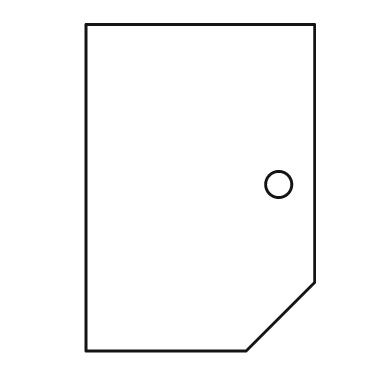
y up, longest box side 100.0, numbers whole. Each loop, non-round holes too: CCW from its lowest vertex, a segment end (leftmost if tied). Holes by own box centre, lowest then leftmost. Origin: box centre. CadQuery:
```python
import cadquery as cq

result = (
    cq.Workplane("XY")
    .moveTo(-35.0, -50.0)
    .lineTo(14.0, -50.0)
    .lineTo(35.0, -29.0)
    .lineTo(35.0, 50.0)
    .lineTo(-35.0, 50.0)
    .close()
    .moveTo(24.0, 1.0)
    .circle(4.0)
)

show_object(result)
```